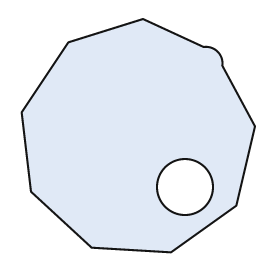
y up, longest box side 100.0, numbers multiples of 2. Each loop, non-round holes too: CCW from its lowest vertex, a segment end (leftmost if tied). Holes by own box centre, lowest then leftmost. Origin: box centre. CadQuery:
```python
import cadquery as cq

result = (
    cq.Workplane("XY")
    .moveTo(14.0, -50.0)
    .lineTo(42.0, -30.0)
    .lineTo(50.0, 4.0)
    .lineTo(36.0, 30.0)
    .threePointArc((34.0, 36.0), (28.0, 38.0))
    .lineTo(2.0, 50.0)
    .lineTo(-30.0, 40.0)
    .lineTo(-50.0, 10.0)
    .lineTo(-46.0, -24.0)
    .lineTo(-20.0, -48.0)
    .close()
    .moveTo(20.0, -22.0)
    .circle(12.0)
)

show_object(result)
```